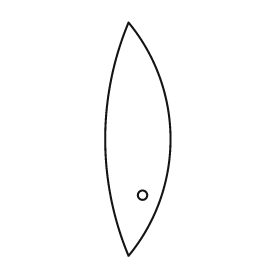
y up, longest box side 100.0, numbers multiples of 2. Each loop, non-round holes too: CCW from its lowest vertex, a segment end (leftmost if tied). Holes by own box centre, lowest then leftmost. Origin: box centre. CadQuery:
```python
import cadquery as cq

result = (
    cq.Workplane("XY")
    .moveTo(-4.0, -50.0)
    .threePointArc((14.0, 0.0), (-4.0, 50.0))
    .threePointArc((-14.0, 0.0), (-4.0, -50.0))
    .close()
    .moveTo(2.0, -24.0)
    .circle(2.0)
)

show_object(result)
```